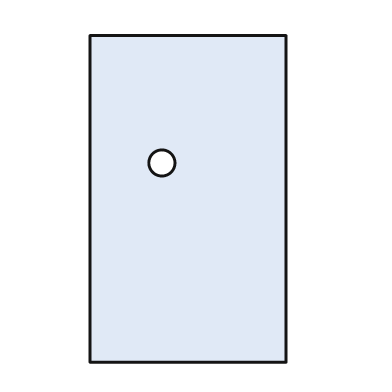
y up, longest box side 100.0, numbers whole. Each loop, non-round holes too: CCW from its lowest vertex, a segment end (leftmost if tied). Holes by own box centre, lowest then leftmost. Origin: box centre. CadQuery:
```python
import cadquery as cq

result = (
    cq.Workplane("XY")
    .moveTo(-30.0, -50.0)
    .lineTo(30.0, -50.0)
    .lineTo(30.0, 50.0)
    .lineTo(-30.0, 50.0)
    .close()
    .moveTo(-8.0, 11.0)
    .circle(4.0)
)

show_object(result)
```